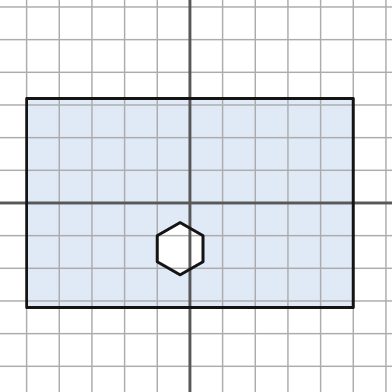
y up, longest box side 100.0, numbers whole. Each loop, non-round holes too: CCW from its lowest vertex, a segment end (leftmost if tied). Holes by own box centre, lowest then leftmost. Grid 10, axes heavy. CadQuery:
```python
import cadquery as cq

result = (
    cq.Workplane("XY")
    .moveTo(-50.0, -32.0)
    .lineTo(50.0, -32.0)
    .lineTo(50.0, 32.0)
    .lineTo(-50.0, 32.0)
    .close()
    .moveTo(-3.0, -22.0)
    .lineTo(4.0, -18.0)
    .lineTo(4.0, -10.0)
    .lineTo(-3.0, -6.0)
    .lineTo(-10.0, -10.0)
    .lineTo(-10.0, -18.0)
    .close()
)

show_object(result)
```